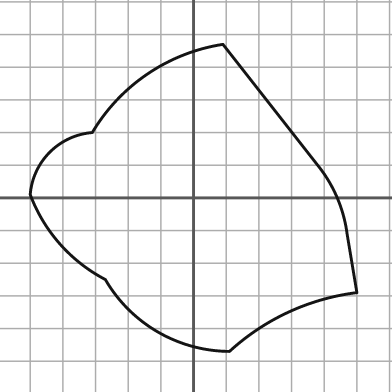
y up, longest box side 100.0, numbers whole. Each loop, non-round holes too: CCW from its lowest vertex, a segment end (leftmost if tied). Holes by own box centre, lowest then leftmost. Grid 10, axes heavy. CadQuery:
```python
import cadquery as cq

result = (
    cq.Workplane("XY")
    .moveTo(11.0, -47.0)
    .threePointArc((29.0, -35.0), (50.0, -29.0))
    .lineTo(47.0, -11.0)
    .threePointArc((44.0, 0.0), (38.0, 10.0))
    .lineTo(9.0, 47.0)
    .threePointArc((-14.0, 38.0), (-31.0, 20.0))
    .threePointArc((-44.0, 14.0), (-50.0, 1.0))
    .threePointArc((-41.0, -14.0), (-27.0, -25.0))
    .threePointArc((-11.0, -41.0), (11.0, -47.0))
    .close()
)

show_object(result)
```